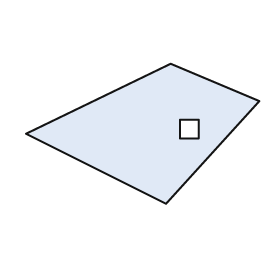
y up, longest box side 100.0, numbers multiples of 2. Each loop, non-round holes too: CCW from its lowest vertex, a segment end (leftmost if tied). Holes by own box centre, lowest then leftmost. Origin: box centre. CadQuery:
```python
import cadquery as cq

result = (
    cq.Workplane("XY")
    .moveTo(10.0, -30.0)
    .lineTo(50.0, 14.0)
    .lineTo(12.0, 30.0)
    .lineTo(-50.0, 0.0)
    .close()
    .moveTo(16.0, -2.0)
    .lineTo(24.0, -2.0)
    .lineTo(24.0, 6.0)
    .lineTo(16.0, 6.0)
    .close()
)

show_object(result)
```